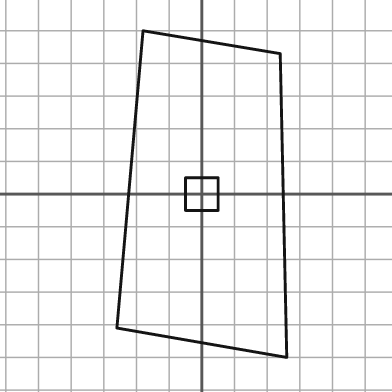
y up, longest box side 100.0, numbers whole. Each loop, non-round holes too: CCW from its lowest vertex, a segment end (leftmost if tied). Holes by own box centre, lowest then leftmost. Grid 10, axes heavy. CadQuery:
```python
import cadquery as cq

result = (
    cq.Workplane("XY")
    .moveTo(26.0, -50.0)
    .lineTo(24.0, 43.0)
    .lineTo(-18.0, 50.0)
    .lineTo(-26.0, -41.0)
    .close()
    .moveTo(-5.0, -5.0)
    .lineTo(5.0, -5.0)
    .lineTo(5.0, 5.0)
    .lineTo(-5.0, 5.0)
    .close()
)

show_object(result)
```